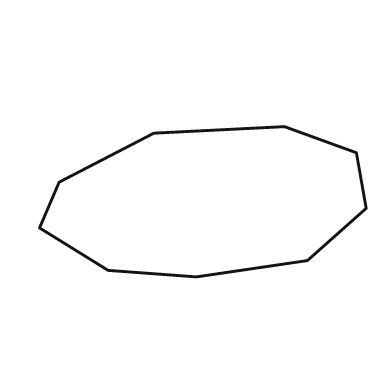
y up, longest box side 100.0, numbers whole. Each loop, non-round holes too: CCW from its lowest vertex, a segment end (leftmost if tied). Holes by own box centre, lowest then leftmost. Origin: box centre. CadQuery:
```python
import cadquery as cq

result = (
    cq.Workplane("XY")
    .moveTo(-2.0, -23.0)
    .lineTo(32.0, -18.0)
    .lineTo(50.0, -2.0)
    .lineTo(47.0, 15.0)
    .lineTo(25.0, 23.0)
    .lineTo(-15.0, 21.0)
    .lineTo(-44.0, 6.0)
    .lineTo(-50.0, -8.0)
    .lineTo(-29.0, -21.0)
    .close()
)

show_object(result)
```